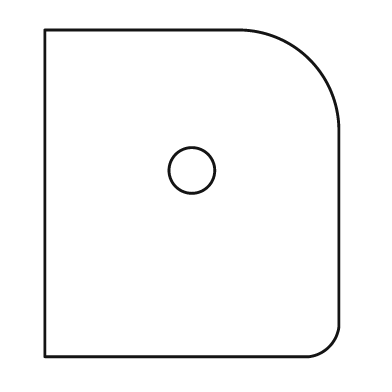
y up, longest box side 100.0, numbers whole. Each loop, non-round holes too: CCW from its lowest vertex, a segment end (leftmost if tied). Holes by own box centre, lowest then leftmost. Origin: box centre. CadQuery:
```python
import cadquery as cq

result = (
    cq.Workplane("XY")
    .moveTo(-45.0, -50.0)
    .lineTo(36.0, -50.0)
    .threePointArc((42.0, -47.0), (45.0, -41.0))
    .lineTo(45.0, 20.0)
    .threePointArc((36.0, 41.0), (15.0, 50.0))
    .lineTo(-45.0, 50.0)
    .close()
    .moveTo(0.0, 7.0)
    .circle(7.0)
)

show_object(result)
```